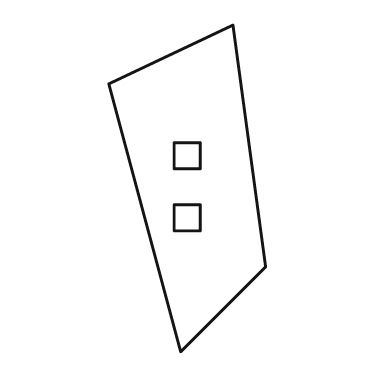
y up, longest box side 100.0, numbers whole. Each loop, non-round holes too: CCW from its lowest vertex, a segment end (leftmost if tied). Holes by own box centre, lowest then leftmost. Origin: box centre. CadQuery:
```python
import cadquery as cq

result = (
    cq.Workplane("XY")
    .moveTo(-2.0, -50.0)
    .lineTo(24.0, -24.0)
    .lineTo(14.0, 50.0)
    .lineTo(-24.0, 32.0)
    .close()
    .moveTo(-4.0, -13.0)
    .lineTo(4.0, -13.0)
    .lineTo(4.0, -5.0)
    .lineTo(-4.0, -5.0)
    .close()
    .moveTo(-4.0, 6.0)
    .lineTo(4.0, 6.0)
    .lineTo(4.0, 14.0)
    .lineTo(-4.0, 14.0)
    .close()
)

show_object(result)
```